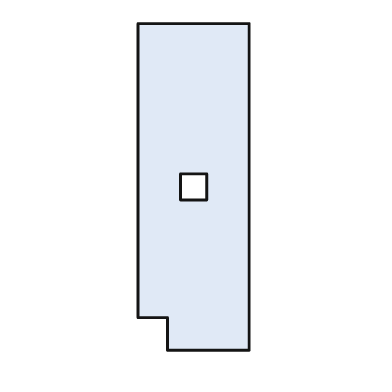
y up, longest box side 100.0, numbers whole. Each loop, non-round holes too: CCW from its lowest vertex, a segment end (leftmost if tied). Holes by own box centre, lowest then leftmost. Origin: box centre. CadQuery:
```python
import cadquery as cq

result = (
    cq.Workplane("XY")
    .moveTo(-8.0, -50.0)
    .lineTo(17.0, -50.0)
    .lineTo(17.0, 50.0)
    .lineTo(-17.0, 50.0)
    .lineTo(-17.0, -40.0)
    .lineTo(-8.0, -40.0)
    .close()
    .moveTo(-4.0, -4.0)
    .lineTo(4.0, -4.0)
    .lineTo(4.0, 4.0)
    .lineTo(-4.0, 4.0)
    .close()
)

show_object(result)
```